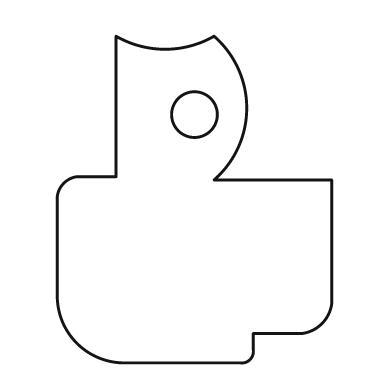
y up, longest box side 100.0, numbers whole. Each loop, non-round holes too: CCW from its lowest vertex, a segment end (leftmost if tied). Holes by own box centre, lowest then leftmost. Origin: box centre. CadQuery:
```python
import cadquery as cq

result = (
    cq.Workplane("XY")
    .moveTo(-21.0, -50.0)
    .lineTo(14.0, -50.0)
    .threePointArc((17.0, -49.0), (18.0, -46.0))
    .lineTo(18.0, -41.0)
    .lineTo(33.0, -41.0)
    .threePointArc((39.0, -38.0), (42.0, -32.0))
    .lineTo(42.0, 6.0)
    .lineTo(6.0, 6.0)
    .threePointArc((16.0, 28.0), (6.0, 50.0))
    .threePointArc((-9.0, 46.0), (-24.0, 50.0))
    .lineTo(-24.0, 7.0)
    .lineTo(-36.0, 7.0)
    .threePointArc((-40.0, 5.0), (-42.0, 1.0))
    .lineTo(-42.0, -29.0)
    .threePointArc((-36.0, -44.0), (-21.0, -50.0))
    .close()
    .moveTo(0.0, 26.0)
    .circle(7.0)
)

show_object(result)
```